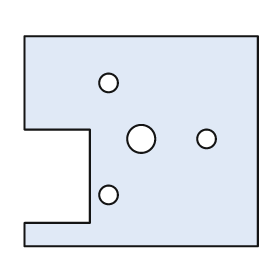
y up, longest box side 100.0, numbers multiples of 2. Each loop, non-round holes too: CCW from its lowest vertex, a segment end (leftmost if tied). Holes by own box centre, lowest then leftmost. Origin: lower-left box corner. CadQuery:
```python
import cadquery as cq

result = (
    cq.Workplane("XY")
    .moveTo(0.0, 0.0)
    .lineTo(100.0, 0.0)
    .lineTo(100.0, 90.0)
    .lineTo(0.0, 90.0)
    .lineTo(0.0, 50.0)
    .lineTo(28.0, 50.0)
    .lineTo(28.0, 10.0)
    .lineTo(0.0, 10.0)
    .close()
    .moveTo(36.0, 22.0)
    .circle(4.0)
    .moveTo(50.0, 46.0)
    .circle(6.0)
    .moveTo(78.0, 46.0)
    .circle(4.0)
    .moveTo(36.0, 70.0)
    .circle(4.0)
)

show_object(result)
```